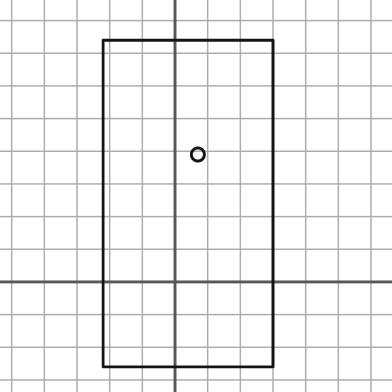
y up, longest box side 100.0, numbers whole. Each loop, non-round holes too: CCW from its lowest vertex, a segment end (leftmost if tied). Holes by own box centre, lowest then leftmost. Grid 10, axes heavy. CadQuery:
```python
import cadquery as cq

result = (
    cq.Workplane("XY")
    .moveTo(-22.0, -26.0)
    .lineTo(30.0, -26.0)
    .lineTo(30.0, 74.0)
    .lineTo(-22.0, 74.0)
    .close()
    .moveTo(7.0, 39.0)
    .circle(2.0)
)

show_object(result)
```